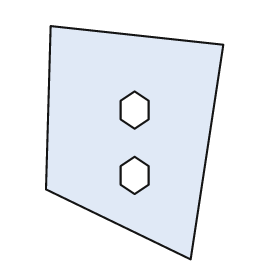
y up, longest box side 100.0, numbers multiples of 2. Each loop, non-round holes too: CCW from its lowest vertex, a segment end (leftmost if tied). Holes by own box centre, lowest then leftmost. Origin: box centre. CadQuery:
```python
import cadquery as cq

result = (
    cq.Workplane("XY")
    .moveTo(24.0, -50.0)
    .lineTo(38.0, 42.0)
    .lineTo(-36.0, 50.0)
    .lineTo(-38.0, -20.0)
    .close()
    .moveTo(0.0, -22.0)
    .lineTo(6.0, -18.0)
    .lineTo(6.0, -10.0)
    .lineTo(0.0, -6.0)
    .lineTo(-6.0, -10.0)
    .lineTo(-6.0, -18.0)
    .close()
    .moveTo(0.0, 6.0)
    .lineTo(6.0, 10.0)
    .lineTo(6.0, 18.0)
    .lineTo(0.0, 22.0)
    .lineTo(-6.0, 18.0)
    .lineTo(-6.0, 10.0)
    .close()
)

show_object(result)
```